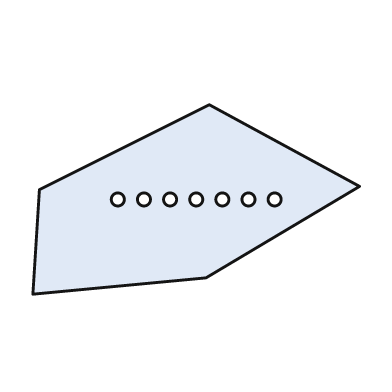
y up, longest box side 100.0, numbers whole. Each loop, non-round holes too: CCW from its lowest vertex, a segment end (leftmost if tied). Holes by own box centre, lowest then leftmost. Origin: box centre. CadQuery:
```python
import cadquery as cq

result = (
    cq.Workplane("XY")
    .moveTo(-50.0, -29.0)
    .lineTo(3.0, -24.0)
    .lineTo(50.0, 4.0)
    .lineTo(4.0, 29.0)
    .lineTo(-48.0, 3.0)
    .close()
    .moveTo(-24.0, 0.0)
    .circle(2.0)
    .moveTo(-16.0, 0.0)
    .circle(2.0)
    .moveTo(-8.0, 0.0)
    .circle(2.0)
    .moveTo(0.0, 0.0)
    .circle(2.0)
    .moveTo(8.0, 0.0)
    .circle(2.0)
    .moveTo(16.0, 0.0)
    .circle(2.0)
    .moveTo(24.0, 0.0)
    .circle(2.0)
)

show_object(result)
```